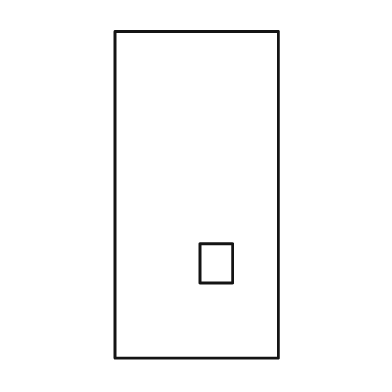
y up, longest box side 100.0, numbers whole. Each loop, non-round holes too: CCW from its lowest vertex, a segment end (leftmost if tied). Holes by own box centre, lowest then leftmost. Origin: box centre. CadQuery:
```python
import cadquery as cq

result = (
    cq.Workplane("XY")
    .moveTo(-25.0, -50.0)
    .lineTo(25.0, -50.0)
    .lineTo(25.0, 50.0)
    .lineTo(-25.0, 50.0)
    .close()
    .moveTo(1.0, -27.0)
    .lineTo(11.0, -27.0)
    .lineTo(11.0, -15.0)
    .lineTo(1.0, -15.0)
    .close()
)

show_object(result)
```